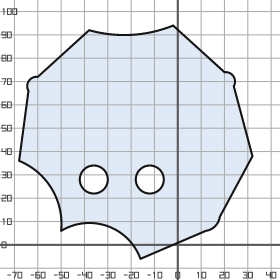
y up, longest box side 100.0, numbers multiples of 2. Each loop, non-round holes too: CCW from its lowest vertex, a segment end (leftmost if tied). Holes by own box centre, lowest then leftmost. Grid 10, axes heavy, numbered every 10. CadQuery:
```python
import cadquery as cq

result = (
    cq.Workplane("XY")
    .moveTo(-16.0, -6.0)
    .lineTo(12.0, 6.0)
    .threePointArc((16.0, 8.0), (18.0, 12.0))
    .lineTo(32.0, 38.0)
    .lineTo(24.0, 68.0)
    .threePointArc((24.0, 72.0), (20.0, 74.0))
    .lineTo(-2.0, 94.0)
    .threePointArc((-20.0, 90.0), (-38.0, 92.0))
    .lineTo(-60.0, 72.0)
    .threePointArc((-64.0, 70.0), (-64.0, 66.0))
    .lineTo(-68.0, 36.0)
    .threePointArc((-54.0, 24.0), (-50.0, 6.0))
    .threePointArc((-30.0, 8.0), (-16.0, -6.0))
    .close()
    .moveTo(-36.0, 28.0)
    .circle(6.0)
    .moveTo(-12.0, 28.0)
    .circle(6.0)
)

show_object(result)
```